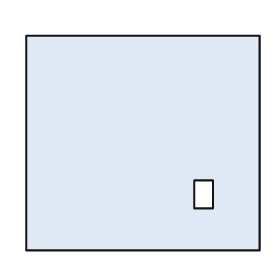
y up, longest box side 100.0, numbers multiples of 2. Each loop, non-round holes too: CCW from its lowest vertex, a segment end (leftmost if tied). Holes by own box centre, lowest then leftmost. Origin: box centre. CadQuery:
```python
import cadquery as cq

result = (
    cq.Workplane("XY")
    .moveTo(-50.0, -46.0)
    .lineTo(50.0, -46.0)
    .lineTo(50.0, 46.0)
    .lineTo(-50.0, 46.0)
    .close()
    .moveTo(22.0, -28.0)
    .lineTo(30.0, -28.0)
    .lineTo(30.0, -16.0)
    .lineTo(22.0, -16.0)
    .close()
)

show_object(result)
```